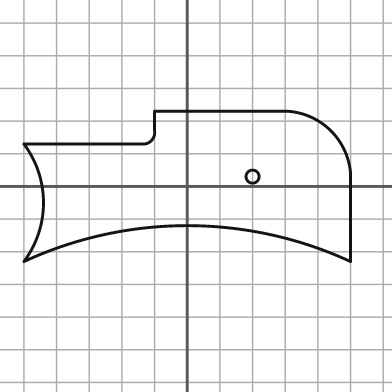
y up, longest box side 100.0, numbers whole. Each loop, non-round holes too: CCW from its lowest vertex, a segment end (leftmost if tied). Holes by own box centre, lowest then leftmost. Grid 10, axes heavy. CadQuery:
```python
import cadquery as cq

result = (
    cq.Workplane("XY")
    .moveTo(-50.0, -23.0)
    .threePointArc((0.0, -12.0), (50.0, -23.0))
    .lineTo(50.0, 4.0)
    .threePointArc((44.0, 17.0), (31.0, 23.0))
    .lineTo(-10.0, 23.0)
    .lineTo(-10.0, 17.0)
    .threePointArc((-11.0, 14.0), (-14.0, 13.0))
    .lineTo(-50.0, 13.0)
    .threePointArc((-44.0, -5.0), (-50.0, -23.0))
    .close()
    .moveTo(20.0, 3.0)
    .circle(2.0)
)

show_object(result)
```